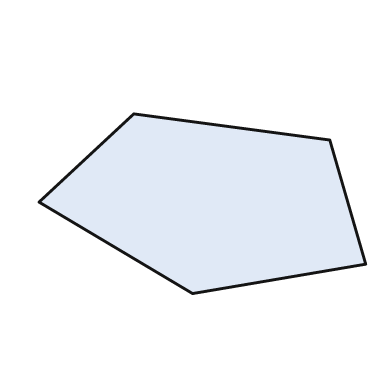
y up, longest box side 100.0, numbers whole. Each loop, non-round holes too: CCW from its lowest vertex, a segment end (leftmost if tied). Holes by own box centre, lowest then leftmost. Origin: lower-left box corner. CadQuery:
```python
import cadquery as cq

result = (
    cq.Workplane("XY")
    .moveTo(47.0, 0.0)
    .lineTo(100.0, 9.0)
    .lineTo(89.0, 47.0)
    .lineTo(29.0, 55.0)
    .lineTo(0.0, 28.0)
    .close()
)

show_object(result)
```